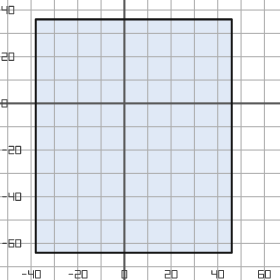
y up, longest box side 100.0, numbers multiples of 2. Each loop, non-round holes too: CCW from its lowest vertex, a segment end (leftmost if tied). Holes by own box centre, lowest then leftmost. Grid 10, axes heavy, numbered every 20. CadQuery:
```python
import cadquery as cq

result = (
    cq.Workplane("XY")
    .moveTo(-38.0, -64.0)
    .lineTo(46.0, -64.0)
    .lineTo(46.0, 36.0)
    .lineTo(-38.0, 36.0)
    .close()
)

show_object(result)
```